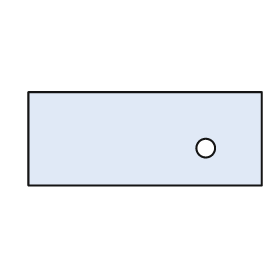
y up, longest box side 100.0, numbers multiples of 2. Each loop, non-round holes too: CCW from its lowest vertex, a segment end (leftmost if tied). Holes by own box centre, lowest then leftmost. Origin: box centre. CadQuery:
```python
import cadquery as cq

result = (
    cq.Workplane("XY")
    .moveTo(-50.0, -20.0)
    .lineTo(50.0, -20.0)
    .lineTo(50.0, 20.0)
    .lineTo(-50.0, 20.0)
    .close()
    .moveTo(26.0, -4.0)
    .circle(4.0)
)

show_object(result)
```